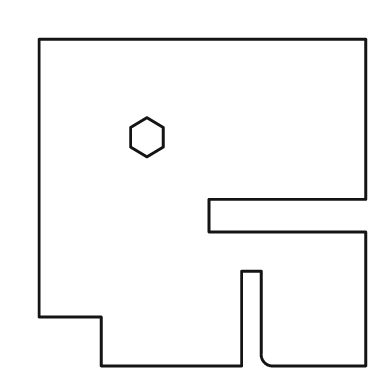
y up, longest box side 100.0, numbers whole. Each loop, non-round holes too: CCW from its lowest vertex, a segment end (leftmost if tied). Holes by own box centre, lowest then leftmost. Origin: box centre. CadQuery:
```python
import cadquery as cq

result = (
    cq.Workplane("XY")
    .moveTo(-31.0, -50.0)
    .lineTo(12.0, -50.0)
    .lineTo(12.0, -21.0)
    .lineTo(18.0, -21.0)
    .lineTo(18.0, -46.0)
    .threePointArc((19.0, -49.0), (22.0, -50.0))
    .lineTo(50.0, -50.0)
    .lineTo(50.0, -9.0)
    .lineTo(2.0, -9.0)
    .lineTo(2.0, 1.0)
    .lineTo(50.0, 1.0)
    .lineTo(50.0, 50.0)
    .lineTo(-50.0, 50.0)
    .lineTo(-50.0, -35.0)
    .lineTo(-31.0, -35.0)
    .close()
    .moveTo(-17.0, 14.0)
    .lineTo(-12.0, 17.0)
    .lineTo(-12.0, 23.0)
    .lineTo(-17.0, 26.0)
    .lineTo(-22.0, 23.0)
    .lineTo(-22.0, 17.0)
    .close()
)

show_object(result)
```